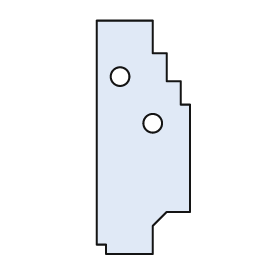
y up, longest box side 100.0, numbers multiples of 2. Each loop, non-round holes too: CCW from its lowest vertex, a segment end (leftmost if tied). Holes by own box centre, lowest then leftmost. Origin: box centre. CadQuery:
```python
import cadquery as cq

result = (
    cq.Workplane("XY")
    .moveTo(-16.0, -50.0)
    .lineTo(4.0, -50.0)
    .lineTo(4.0, -38.0)
    .lineTo(10.0, -32.0)
    .lineTo(20.0, -32.0)
    .lineTo(20.0, 14.0)
    .lineTo(16.0, 14.0)
    .lineTo(16.0, 24.0)
    .lineTo(10.0, 24.0)
    .lineTo(10.0, 36.0)
    .lineTo(4.0, 36.0)
    .lineTo(4.0, 50.0)
    .lineTo(-20.0, 50.0)
    .lineTo(-20.0, -46.0)
    .lineTo(-16.0, -46.0)
    .close()
    .moveTo(4.0, 6.0)
    .circle(4.0)
    .moveTo(-10.0, 26.0)
    .circle(4.0)
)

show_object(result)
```